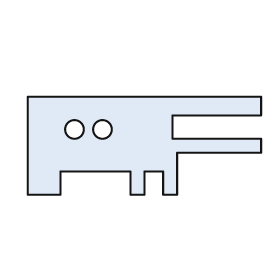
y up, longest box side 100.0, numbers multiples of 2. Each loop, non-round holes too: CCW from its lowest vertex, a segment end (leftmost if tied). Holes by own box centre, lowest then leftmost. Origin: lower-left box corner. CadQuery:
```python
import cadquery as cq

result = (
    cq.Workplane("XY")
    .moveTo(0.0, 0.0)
    .lineTo(14.0, 0.0)
    .lineTo(14.0, 10.0)
    .lineTo(44.0, 10.0)
    .lineTo(44.0, 0.0)
    .lineTo(50.0, 0.0)
    .lineTo(50.0, 10.0)
    .lineTo(58.0, 10.0)
    .lineTo(58.0, 0.0)
    .lineTo(64.0, 0.0)
    .lineTo(64.0, 18.0)
    .lineTo(100.0, 18.0)
    .lineTo(100.0, 24.0)
    .lineTo(62.0, 24.0)
    .lineTo(62.0, 34.0)
    .lineTo(100.0, 34.0)
    .lineTo(100.0, 42.0)
    .lineTo(0.0, 42.0)
    .close()
    .moveTo(20.0, 28.0)
    .circle(4.0)
    .moveTo(32.0, 28.0)
    .circle(4.0)
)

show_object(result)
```